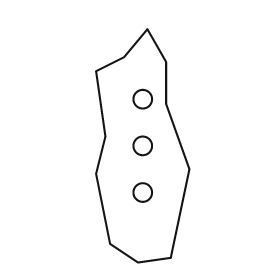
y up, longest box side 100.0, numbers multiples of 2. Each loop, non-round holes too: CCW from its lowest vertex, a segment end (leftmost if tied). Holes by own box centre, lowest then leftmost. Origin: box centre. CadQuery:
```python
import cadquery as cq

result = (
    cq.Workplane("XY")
    .moveTo(-2.0, -50.0)
    .lineTo(12.0, -48.0)
    .lineTo(20.0, -10.0)
    .lineTo(10.0, 18.0)
    .lineTo(10.0, 36.0)
    .lineTo(2.0, 50.0)
    .lineTo(-8.0, 38.0)
    .lineTo(-20.0, 32.0)
    .lineTo(-16.0, 4.0)
    .lineTo(-20.0, -12.0)
    .lineTo(-14.0, -42.0)
    .close()
    .moveTo(0.0, -20.0)
    .circle(4.0)
    .moveTo(0.0, 0.0)
    .circle(4.0)
    .moveTo(0.0, 20.0)
    .circle(4.0)
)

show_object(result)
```